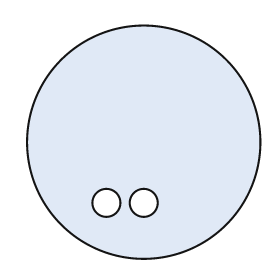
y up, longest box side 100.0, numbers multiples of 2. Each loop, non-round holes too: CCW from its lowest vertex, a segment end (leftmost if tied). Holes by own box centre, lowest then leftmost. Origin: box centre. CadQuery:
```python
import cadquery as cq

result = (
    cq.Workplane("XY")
    .moveTo(0.0, 0.0)
    .circle(50.0)
    .moveTo(-16.0, -26.0)
    .circle(6.0)
    .moveTo(0.0, -26.0)
    .circle(6.0)
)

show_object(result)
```